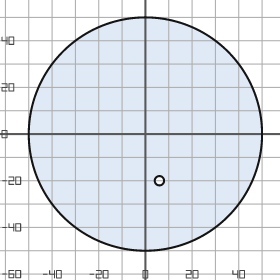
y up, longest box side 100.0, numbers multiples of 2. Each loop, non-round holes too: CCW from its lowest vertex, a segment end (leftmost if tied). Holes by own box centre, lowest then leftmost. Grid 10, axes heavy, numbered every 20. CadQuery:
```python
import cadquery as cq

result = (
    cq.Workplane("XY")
    .moveTo(0.0, 0.0)
    .circle(50.0)
    .moveTo(6.0, -20.0)
    .circle(2.0)
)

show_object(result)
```